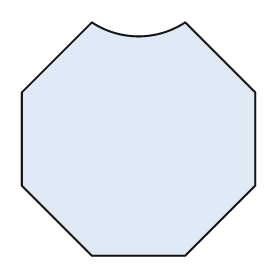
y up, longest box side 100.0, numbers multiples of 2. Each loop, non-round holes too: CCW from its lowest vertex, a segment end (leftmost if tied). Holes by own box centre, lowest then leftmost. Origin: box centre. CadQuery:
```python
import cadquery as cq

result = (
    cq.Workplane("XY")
    .moveTo(-20.0, -50.0)
    .lineTo(20.0, -50.0)
    .lineTo(50.0, -20.0)
    .lineTo(50.0, 20.0)
    .lineTo(20.0, 50.0)
    .threePointArc((0.0, 44.0), (-20.0, 50.0))
    .lineTo(-50.0, 20.0)
    .lineTo(-50.0, -20.0)
    .close()
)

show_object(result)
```